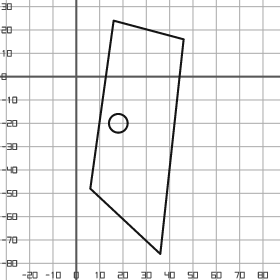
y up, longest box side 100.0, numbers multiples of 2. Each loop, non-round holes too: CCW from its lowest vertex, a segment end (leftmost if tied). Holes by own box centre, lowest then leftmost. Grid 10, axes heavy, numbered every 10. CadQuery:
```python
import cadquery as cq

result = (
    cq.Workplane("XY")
    .moveTo(36.0, -76.0)
    .lineTo(46.0, 16.0)
    .lineTo(16.0, 24.0)
    .lineTo(6.0, -48.0)
    .close()
    .moveTo(18.0, -20.0)
    .circle(4.0)
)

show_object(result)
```